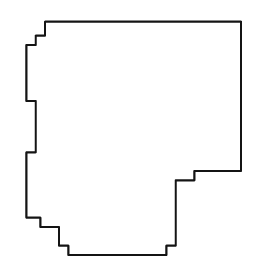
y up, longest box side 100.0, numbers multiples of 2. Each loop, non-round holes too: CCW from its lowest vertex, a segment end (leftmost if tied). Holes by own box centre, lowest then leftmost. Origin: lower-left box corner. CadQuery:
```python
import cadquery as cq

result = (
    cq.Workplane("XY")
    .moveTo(18.0, 0.0)
    .lineTo(60.0, 0.0)
    .lineTo(60.0, 4.0)
    .lineTo(64.0, 4.0)
    .lineTo(64.0, 32.0)
    .lineTo(72.0, 32.0)
    .lineTo(72.0, 36.0)
    .lineTo(92.0, 36.0)
    .lineTo(92.0, 100.0)
    .lineTo(8.0, 100.0)
    .lineTo(8.0, 94.0)
    .lineTo(4.0, 94.0)
    .lineTo(4.0, 90.0)
    .lineTo(0.0, 90.0)
    .lineTo(0.0, 66.0)
    .lineTo(4.0, 66.0)
    .lineTo(4.0, 44.0)
    .lineTo(0.0, 44.0)
    .lineTo(0.0, 16.0)
    .lineTo(6.0, 16.0)
    .lineTo(6.0, 12.0)
    .lineTo(14.0, 12.0)
    .lineTo(14.0, 4.0)
    .lineTo(18.0, 4.0)
    .close()
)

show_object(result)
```